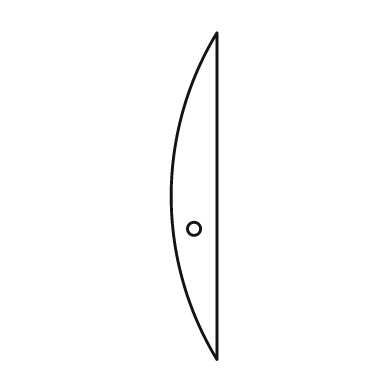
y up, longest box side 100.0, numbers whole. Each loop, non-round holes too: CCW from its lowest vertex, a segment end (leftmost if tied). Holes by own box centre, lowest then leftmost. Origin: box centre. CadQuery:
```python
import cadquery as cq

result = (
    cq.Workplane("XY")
    .moveTo(7.0, -50.0)
    .lineTo(7.0, 50.0)
    .threePointArc((-7.0, 0.0), (7.0, -50.0))
    .close()
    .moveTo(0.0, -10.0)
    .circle(2.0)
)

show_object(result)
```